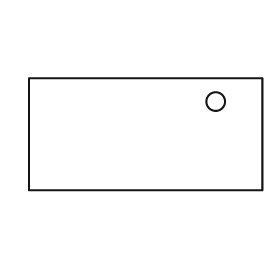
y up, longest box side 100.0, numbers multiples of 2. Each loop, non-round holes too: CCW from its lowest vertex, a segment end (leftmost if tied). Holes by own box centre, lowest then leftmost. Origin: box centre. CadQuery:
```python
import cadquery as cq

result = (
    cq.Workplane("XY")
    .moveTo(-50.0, -24.0)
    .lineTo(50.0, -24.0)
    .lineTo(50.0, 24.0)
    .lineTo(-50.0, 24.0)
    .close()
    .moveTo(30.0, 14.0)
    .circle(4.0)
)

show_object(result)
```